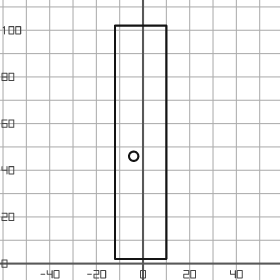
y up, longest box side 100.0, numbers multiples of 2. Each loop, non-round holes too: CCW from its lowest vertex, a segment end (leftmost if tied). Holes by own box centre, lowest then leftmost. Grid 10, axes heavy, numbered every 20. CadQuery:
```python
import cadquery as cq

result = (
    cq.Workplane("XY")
    .moveTo(-12.0, 2.0)
    .lineTo(10.0, 2.0)
    .lineTo(10.0, 102.0)
    .lineTo(-12.0, 102.0)
    .close()
    .moveTo(-4.0, 46.0)
    .circle(2.0)
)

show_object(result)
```